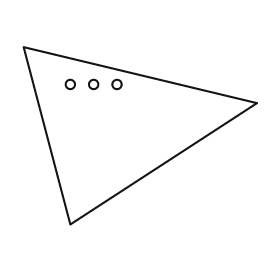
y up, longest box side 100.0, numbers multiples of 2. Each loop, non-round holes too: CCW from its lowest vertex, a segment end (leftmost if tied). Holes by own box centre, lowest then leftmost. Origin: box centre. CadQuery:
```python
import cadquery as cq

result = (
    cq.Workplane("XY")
    .moveTo(-30.0, -38.0)
    .lineTo(50.0, 14.0)
    .lineTo(-50.0, 38.0)
    .close()
    .moveTo(-30.0, 22.0)
    .circle(2.0)
    .moveTo(-20.0, 22.0)
    .circle(2.0)
    .moveTo(-10.0, 22.0)
    .circle(2.0)
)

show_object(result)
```